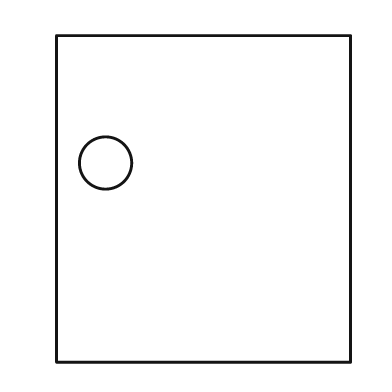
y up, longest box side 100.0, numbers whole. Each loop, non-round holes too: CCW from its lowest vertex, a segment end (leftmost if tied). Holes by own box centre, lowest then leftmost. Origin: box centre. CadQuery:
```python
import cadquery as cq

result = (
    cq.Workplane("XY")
    .moveTo(-45.0, -50.0)
    .lineTo(45.0, -50.0)
    .lineTo(45.0, 50.0)
    .lineTo(-45.0, 50.0)
    .close()
    .moveTo(-30.0, 11.0)
    .circle(8.0)
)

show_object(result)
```